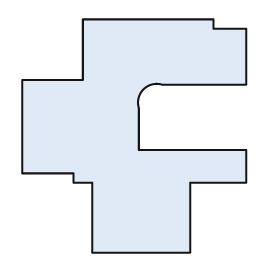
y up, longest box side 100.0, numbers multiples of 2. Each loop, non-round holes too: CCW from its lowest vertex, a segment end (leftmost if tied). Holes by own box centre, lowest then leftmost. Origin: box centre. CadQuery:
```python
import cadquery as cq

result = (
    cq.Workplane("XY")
    .moveTo(-18.0, -50.0)
    .lineTo(24.0, -50.0)
    .lineTo(24.0, -20.0)
    .lineTo(48.0, -20.0)
    .lineTo(48.0, -6.0)
    .lineTo(2.0, -6.0)
    .lineTo(2.0, 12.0)
    .threePointArc((4.0, 20.0), (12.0, 22.0))
    .lineTo(48.0, 22.0)
    .lineTo(48.0, 46.0)
    .lineTo(34.0, 46.0)
    .lineTo(34.0, 50.0)
    .lineTo(-22.0, 50.0)
    .lineTo(-22.0, 24.0)
    .lineTo(-48.0, 24.0)
    .lineTo(-48.0, -16.0)
    .lineTo(-26.0, -16.0)
    .lineTo(-26.0, -20.0)
    .lineTo(-18.0, -20.0)
    .close()
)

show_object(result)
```